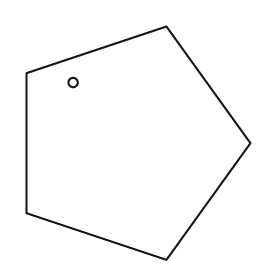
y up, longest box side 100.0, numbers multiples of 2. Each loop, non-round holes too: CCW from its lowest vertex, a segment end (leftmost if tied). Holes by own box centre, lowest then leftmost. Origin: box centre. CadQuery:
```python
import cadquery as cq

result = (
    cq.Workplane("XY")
    .moveTo(12.0, -50.0)
    .lineTo(48.0, 0.0)
    .lineTo(12.0, 50.0)
    .lineTo(-48.0, 30.0)
    .lineTo(-48.0, -30.0)
    .close()
    .moveTo(-28.0, 26.0)
    .circle(2.0)
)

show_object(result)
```